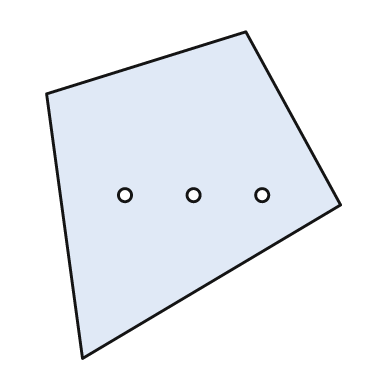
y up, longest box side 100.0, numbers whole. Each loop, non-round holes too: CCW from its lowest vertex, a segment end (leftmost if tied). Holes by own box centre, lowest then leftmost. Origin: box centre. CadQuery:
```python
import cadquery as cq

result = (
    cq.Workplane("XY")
    .moveTo(-34.0, -50.0)
    .lineTo(45.0, -3.0)
    .lineTo(16.0, 50.0)
    .lineTo(-45.0, 31.0)
    .close()
    .moveTo(-21.0, 0.0)
    .circle(2.0)
    .moveTo(0.0, 0.0)
    .circle(2.0)
    .moveTo(21.0, 0.0)
    .circle(2.0)
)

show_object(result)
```